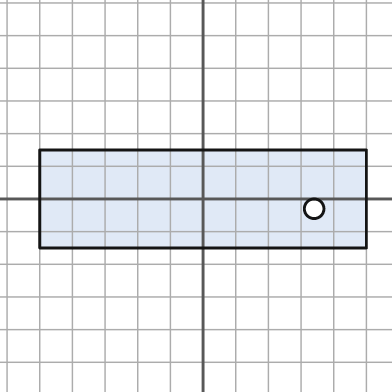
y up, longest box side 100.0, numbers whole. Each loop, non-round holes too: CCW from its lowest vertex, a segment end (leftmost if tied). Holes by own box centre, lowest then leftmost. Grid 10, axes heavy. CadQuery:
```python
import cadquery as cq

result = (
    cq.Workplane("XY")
    .moveTo(-50.0, -15.0)
    .lineTo(50.0, -15.0)
    .lineTo(50.0, 15.0)
    .lineTo(-50.0, 15.0)
    .close()
    .moveTo(34.0, -3.0)
    .circle(3.0)
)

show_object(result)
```